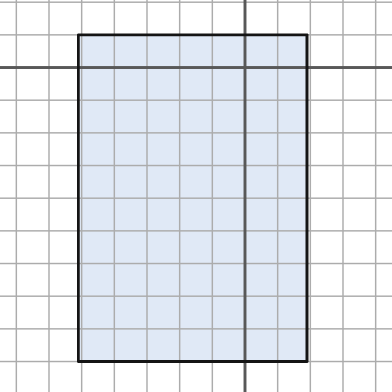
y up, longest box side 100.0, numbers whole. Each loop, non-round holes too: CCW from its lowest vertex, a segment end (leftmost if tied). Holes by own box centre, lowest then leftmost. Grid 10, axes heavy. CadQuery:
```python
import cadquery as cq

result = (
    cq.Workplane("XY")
    .moveTo(-51.0, -90.0)
    .lineTo(19.0, -90.0)
    .lineTo(19.0, 10.0)
    .lineTo(-51.0, 10.0)
    .close()
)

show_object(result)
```